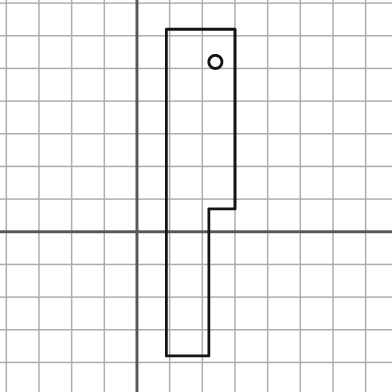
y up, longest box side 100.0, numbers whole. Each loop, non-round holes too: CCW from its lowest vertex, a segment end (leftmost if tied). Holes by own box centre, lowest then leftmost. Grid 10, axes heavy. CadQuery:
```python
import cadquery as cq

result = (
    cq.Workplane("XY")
    .moveTo(9.0, -38.0)
    .lineTo(22.0, -38.0)
    .lineTo(22.0, 7.0)
    .lineTo(30.0, 7.0)
    .lineTo(30.0, 62.0)
    .lineTo(9.0, 62.0)
    .close()
    .moveTo(24.0, 52.0)
    .circle(2.0)
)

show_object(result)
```